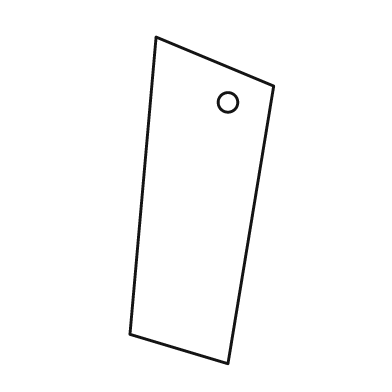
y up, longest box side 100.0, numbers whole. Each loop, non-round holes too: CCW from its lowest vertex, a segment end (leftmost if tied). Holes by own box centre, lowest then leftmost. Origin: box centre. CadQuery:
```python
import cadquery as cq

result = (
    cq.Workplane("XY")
    .moveTo(8.0, -50.0)
    .lineTo(22.0, 35.0)
    .lineTo(-14.0, 50.0)
    .lineTo(-22.0, -41.0)
    .close()
    .moveTo(8.0, 30.0)
    .circle(3.0)
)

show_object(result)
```